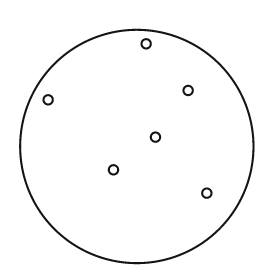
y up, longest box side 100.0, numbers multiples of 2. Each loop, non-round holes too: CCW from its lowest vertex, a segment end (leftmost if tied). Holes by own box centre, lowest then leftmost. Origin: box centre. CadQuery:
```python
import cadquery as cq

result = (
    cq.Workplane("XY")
    .moveTo(0.0, 0.0)
    .circle(50.0)
    .moveTo(30.0, -20.0)
    .circle(2.0)
    .moveTo(-10.0, -10.0)
    .circle(2.0)
    .moveTo(8.0, 4.0)
    .circle(2.0)
    .moveTo(-38.0, 20.0)
    .circle(2.0)
    .moveTo(22.0, 24.0)
    .circle(2.0)
    .moveTo(4.0, 44.0)
    .circle(2.0)
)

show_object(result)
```